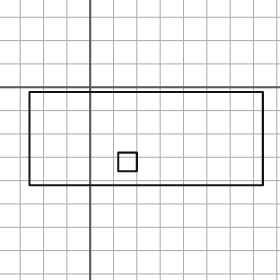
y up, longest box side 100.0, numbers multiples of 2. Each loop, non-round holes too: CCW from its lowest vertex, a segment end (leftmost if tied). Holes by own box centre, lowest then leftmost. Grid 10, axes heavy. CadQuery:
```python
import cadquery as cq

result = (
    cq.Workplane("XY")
    .moveTo(-26.0, -42.0)
    .lineTo(74.0, -42.0)
    .lineTo(74.0, -2.0)
    .lineTo(-26.0, -2.0)
    .close()
    .moveTo(12.0, -36.0)
    .lineTo(20.0, -36.0)
    .lineTo(20.0, -28.0)
    .lineTo(12.0, -28.0)
    .close()
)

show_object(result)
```